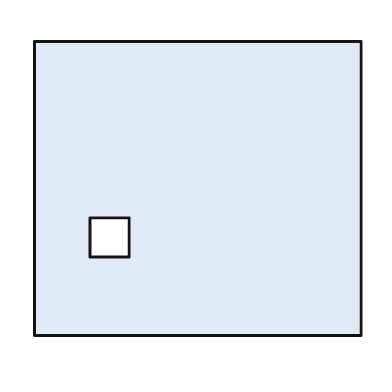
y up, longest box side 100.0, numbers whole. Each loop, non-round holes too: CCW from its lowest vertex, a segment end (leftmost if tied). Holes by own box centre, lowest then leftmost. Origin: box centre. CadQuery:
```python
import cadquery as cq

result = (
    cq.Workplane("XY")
    .moveTo(-50.0, -45.0)
    .lineTo(50.0, -45.0)
    .lineTo(50.0, 45.0)
    .lineTo(-50.0, 45.0)
    .close()
    .moveTo(-33.0, -21.0)
    .lineTo(-21.0, -21.0)
    .lineTo(-21.0, -9.0)
    .lineTo(-33.0, -9.0)
    .close()
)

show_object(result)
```